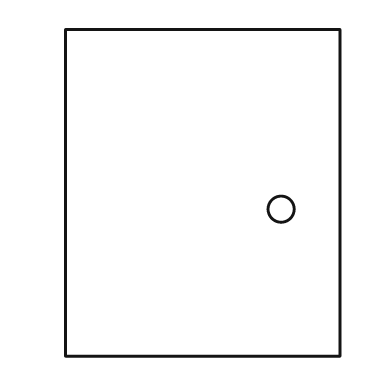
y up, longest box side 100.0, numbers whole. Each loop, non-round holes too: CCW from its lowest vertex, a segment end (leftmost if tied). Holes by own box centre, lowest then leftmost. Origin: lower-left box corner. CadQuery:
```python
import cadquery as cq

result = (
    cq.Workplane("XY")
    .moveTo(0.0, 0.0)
    .lineTo(84.0, 0.0)
    .lineTo(84.0, 100.0)
    .lineTo(0.0, 100.0)
    .close()
    .moveTo(66.0, 45.0)
    .circle(4.0)
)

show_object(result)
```